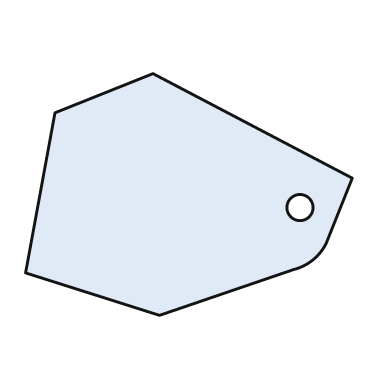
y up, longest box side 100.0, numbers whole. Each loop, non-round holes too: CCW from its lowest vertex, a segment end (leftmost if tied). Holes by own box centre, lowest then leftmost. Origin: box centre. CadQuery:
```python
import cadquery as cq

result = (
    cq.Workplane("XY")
    .moveTo(-9.0, -37.0)
    .lineTo(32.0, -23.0)
    .threePointArc((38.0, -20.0), (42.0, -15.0))
    .lineTo(50.0, 5.0)
    .lineTo(-11.0, 37.0)
    .lineTo(-41.0, 25.0)
    .lineTo(-50.0, -24.0)
    .close()
    .moveTo(34.0, -4.0)
    .circle(4.0)
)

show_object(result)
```